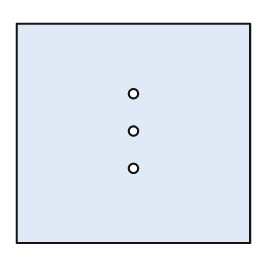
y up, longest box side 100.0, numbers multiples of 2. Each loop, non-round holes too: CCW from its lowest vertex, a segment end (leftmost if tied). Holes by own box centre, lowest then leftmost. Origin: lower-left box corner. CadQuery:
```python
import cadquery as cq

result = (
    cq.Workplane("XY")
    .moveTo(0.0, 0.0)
    .lineTo(100.0, 0.0)
    .lineTo(100.0, 94.0)
    .lineTo(0.0, 94.0)
    .close()
    .moveTo(50.0, 32.0)
    .circle(2.0)
    .moveTo(50.0, 48.0)
    .circle(2.0)
    .moveTo(50.0, 64.0)
    .circle(2.0)
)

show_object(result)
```